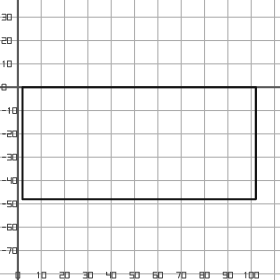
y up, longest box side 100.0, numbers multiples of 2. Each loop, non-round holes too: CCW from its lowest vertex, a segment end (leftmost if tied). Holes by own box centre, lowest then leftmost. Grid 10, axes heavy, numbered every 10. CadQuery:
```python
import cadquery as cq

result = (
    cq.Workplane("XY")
    .moveTo(2.0, -48.0)
    .lineTo(102.0, -48.0)
    .lineTo(102.0, 0.0)
    .lineTo(2.0, 0.0)
    .close()
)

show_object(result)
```